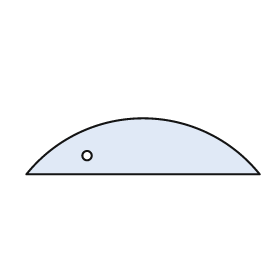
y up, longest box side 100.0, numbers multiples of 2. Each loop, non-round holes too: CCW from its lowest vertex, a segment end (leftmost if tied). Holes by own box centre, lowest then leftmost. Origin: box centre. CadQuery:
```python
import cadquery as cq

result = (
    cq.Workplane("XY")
    .moveTo(-50.0, -12.0)
    .lineTo(50.0, -12.0)
    .threePointArc((0.0, 12.0), (-50.0, -12.0))
    .close()
    .moveTo(-24.0, -4.0)
    .circle(2.0)
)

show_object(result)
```